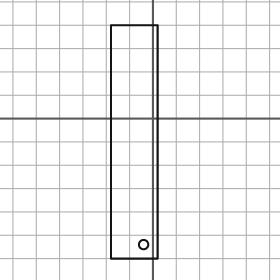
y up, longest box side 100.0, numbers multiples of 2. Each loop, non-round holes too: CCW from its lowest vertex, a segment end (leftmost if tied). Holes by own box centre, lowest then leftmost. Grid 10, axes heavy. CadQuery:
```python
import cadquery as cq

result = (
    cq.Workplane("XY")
    .moveTo(-18.0, -60.0)
    .lineTo(2.0, -60.0)
    .lineTo(2.0, 40.0)
    .lineTo(-18.0, 40.0)
    .close()
    .moveTo(-4.0, -54.0)
    .circle(2.0)
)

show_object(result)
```